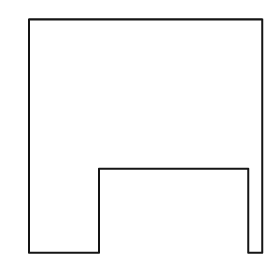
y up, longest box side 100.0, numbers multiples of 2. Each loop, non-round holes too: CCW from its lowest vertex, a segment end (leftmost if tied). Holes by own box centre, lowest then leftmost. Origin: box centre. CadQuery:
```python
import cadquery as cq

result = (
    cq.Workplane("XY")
    .moveTo(-50.0, -50.0)
    .lineTo(-20.0, -50.0)
    .lineTo(-20.0, -14.0)
    .lineTo(44.0, -14.0)
    .lineTo(44.0, -50.0)
    .lineTo(50.0, -50.0)
    .lineTo(50.0, 50.0)
    .lineTo(-50.0, 50.0)
    .close()
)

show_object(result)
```